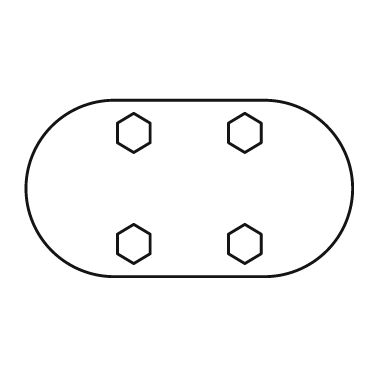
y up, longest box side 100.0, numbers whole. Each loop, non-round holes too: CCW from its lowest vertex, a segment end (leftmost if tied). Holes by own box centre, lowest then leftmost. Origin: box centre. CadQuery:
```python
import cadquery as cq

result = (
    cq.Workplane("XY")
    .moveTo(-23.0, -27.0)
    .lineTo(23.0, -27.0)
    .threePointArc((50.0, 0.0), (23.0, 27.0))
    .lineTo(-23.0, 27.0)
    .threePointArc((-50.0, 0.0), (-23.0, -27.0))
    .close()
    .moveTo(-17.0, -23.0)
    .lineTo(-12.0, -20.0)
    .lineTo(-12.0, -14.0)
    .lineTo(-17.0, -11.0)
    .lineTo(-22.0, -14.0)
    .lineTo(-22.0, -20.0)
    .close()
    .moveTo(17.0, -23.0)
    .lineTo(22.0, -20.0)
    .lineTo(22.0, -14.0)
    .lineTo(17.0, -11.0)
    .lineTo(12.0, -14.0)
    .lineTo(12.0, -20.0)
    .close()
    .moveTo(-17.0, 11.0)
    .lineTo(-12.0, 14.0)
    .lineTo(-12.0, 20.0)
    .lineTo(-17.0, 23.0)
    .lineTo(-22.0, 20.0)
    .lineTo(-22.0, 14.0)
    .close()
    .moveTo(17.0, 11.0)
    .lineTo(22.0, 14.0)
    .lineTo(22.0, 20.0)
    .lineTo(17.0, 23.0)
    .lineTo(12.0, 20.0)
    .lineTo(12.0, 14.0)
    .close()
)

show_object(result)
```